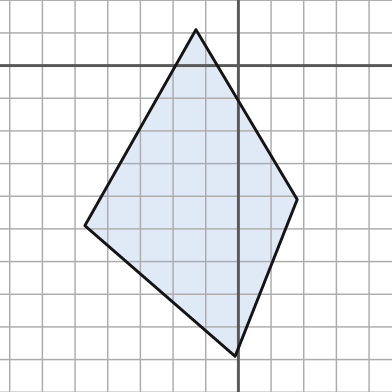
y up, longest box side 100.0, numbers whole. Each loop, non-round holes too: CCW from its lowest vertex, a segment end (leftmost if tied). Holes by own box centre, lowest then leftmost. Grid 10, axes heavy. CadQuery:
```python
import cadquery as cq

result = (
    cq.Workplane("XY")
    .moveTo(-1.0, -89.0)
    .lineTo(18.0, -41.0)
    .lineTo(-13.0, 11.0)
    .lineTo(-47.0, -49.0)
    .close()
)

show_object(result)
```